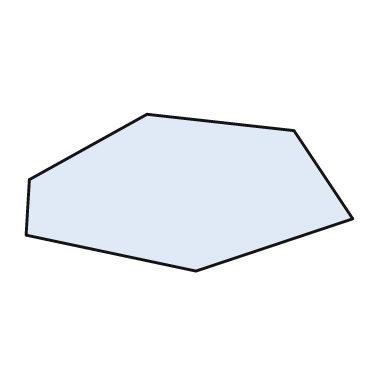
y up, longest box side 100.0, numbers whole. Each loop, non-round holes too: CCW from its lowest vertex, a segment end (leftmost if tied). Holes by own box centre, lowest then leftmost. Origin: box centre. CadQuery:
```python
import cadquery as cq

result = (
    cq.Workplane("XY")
    .moveTo(2.0, -24.0)
    .lineTo(50.0, -8.0)
    .lineTo(32.0, 19.0)
    .lineTo(-13.0, 24.0)
    .lineTo(-49.0, 4.0)
    .lineTo(-50.0, -13.0)
    .close()
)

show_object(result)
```